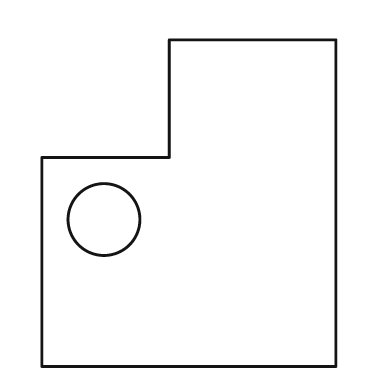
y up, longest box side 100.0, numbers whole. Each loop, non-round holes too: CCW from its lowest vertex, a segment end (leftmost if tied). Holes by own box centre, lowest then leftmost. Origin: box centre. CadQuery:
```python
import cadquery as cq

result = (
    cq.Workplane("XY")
    .moveTo(-45.0, -50.0)
    .lineTo(45.0, -50.0)
    .lineTo(45.0, 50.0)
    .lineTo(-6.0, 50.0)
    .lineTo(-6.0, 14.0)
    .lineTo(-45.0, 14.0)
    .close()
    .moveTo(-26.0, -5.0)
    .circle(11.0)
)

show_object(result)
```